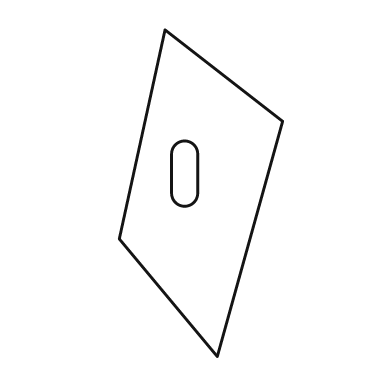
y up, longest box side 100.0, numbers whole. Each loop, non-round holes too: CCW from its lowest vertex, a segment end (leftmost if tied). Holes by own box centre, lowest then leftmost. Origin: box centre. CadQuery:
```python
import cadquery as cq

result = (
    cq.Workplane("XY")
    .moveTo(5.0, -50.0)
    .lineTo(25.0, 22.0)
    .lineTo(-11.0, 50.0)
    .lineTo(-25.0, -14.0)
    .close()
    .moveTo(-9.0, 0.0)
    .threePointArc((-5.0, -4.0), (-1.0, 0.0))
    .lineTo(-1.0, 12.0)
    .threePointArc((-5.0, 16.0), (-9.0, 12.0))
    .close()
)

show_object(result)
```